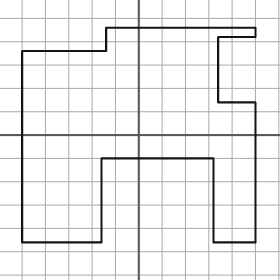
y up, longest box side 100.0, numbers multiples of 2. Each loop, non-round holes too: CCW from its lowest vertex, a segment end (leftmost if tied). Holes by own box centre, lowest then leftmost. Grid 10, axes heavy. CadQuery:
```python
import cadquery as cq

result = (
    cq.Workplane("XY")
    .moveTo(-50.0, -46.0)
    .lineTo(-16.0, -46.0)
    .lineTo(-16.0, -10.0)
    .lineTo(32.0, -10.0)
    .lineTo(32.0, -46.0)
    .lineTo(50.0, -46.0)
    .lineTo(50.0, 14.0)
    .lineTo(34.0, 14.0)
    .lineTo(34.0, 42.0)
    .lineTo(50.0, 42.0)
    .lineTo(50.0, 46.0)
    .lineTo(-14.0, 46.0)
    .lineTo(-14.0, 36.0)
    .lineTo(-50.0, 36.0)
    .close()
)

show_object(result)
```